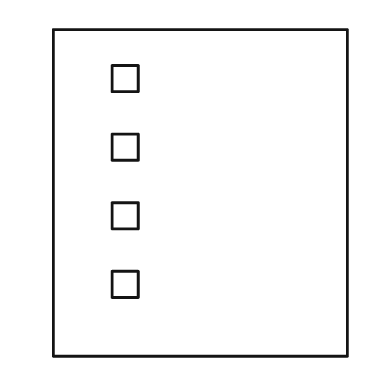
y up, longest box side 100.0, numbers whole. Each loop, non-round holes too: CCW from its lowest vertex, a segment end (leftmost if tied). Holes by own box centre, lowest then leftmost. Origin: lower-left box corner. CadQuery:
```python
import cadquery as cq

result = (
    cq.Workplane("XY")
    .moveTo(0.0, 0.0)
    .lineTo(90.0, 0.0)
    .lineTo(90.0, 100.0)
    .lineTo(0.0, 100.0)
    .close()
    .moveTo(18.0, 18.0)
    .lineTo(26.0, 18.0)
    .lineTo(26.0, 26.0)
    .lineTo(18.0, 26.0)
    .close()
    .moveTo(18.0, 39.0)
    .lineTo(26.0, 39.0)
    .lineTo(26.0, 47.0)
    .lineTo(18.0, 47.0)
    .close()
    .moveTo(18.0, 60.0)
    .lineTo(26.0, 60.0)
    .lineTo(26.0, 68.0)
    .lineTo(18.0, 68.0)
    .close()
    .moveTo(18.0, 81.0)
    .lineTo(26.0, 81.0)
    .lineTo(26.0, 89.0)
    .lineTo(18.0, 89.0)
    .close()
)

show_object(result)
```